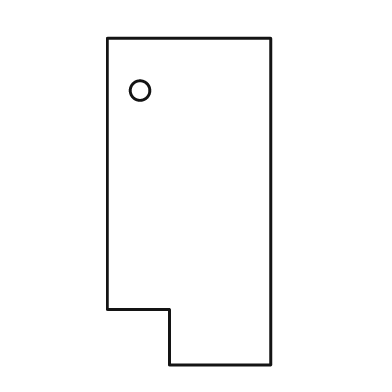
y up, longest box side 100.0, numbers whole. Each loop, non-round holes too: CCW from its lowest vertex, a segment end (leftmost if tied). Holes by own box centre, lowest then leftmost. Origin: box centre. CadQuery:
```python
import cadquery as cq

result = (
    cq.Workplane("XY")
    .moveTo(-6.0, -50.0)
    .lineTo(25.0, -50.0)
    .lineTo(25.0, 50.0)
    .lineTo(-25.0, 50.0)
    .lineTo(-25.0, -33.0)
    .lineTo(-6.0, -33.0)
    .close()
    .moveTo(-15.0, 34.0)
    .circle(3.0)
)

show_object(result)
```